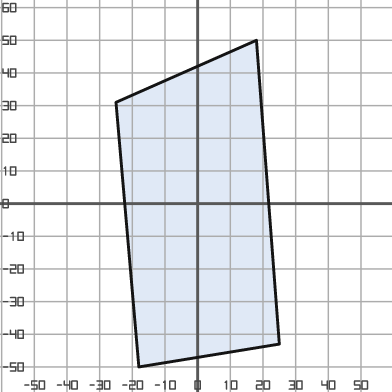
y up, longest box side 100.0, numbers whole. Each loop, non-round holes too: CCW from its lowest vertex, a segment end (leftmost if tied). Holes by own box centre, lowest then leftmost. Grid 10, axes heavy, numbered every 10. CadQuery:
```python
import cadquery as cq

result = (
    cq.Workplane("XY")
    .moveTo(-18.0, -50.0)
    .lineTo(25.0, -43.0)
    .lineTo(18.0, 50.0)
    .lineTo(-25.0, 31.0)
    .close()
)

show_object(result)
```